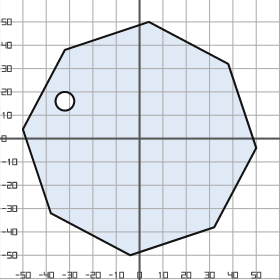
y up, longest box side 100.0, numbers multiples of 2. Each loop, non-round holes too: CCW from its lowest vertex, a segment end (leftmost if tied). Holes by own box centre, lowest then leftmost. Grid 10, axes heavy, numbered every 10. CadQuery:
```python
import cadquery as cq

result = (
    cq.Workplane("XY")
    .moveTo(-4.0, -50.0)
    .lineTo(32.0, -38.0)
    .lineTo(50.0, -4.0)
    .lineTo(38.0, 32.0)
    .lineTo(4.0, 50.0)
    .lineTo(-32.0, 38.0)
    .lineTo(-50.0, 4.0)
    .lineTo(-38.0, -32.0)
    .close()
    .moveTo(-32.0, 16.0)
    .circle(4.0)
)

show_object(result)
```